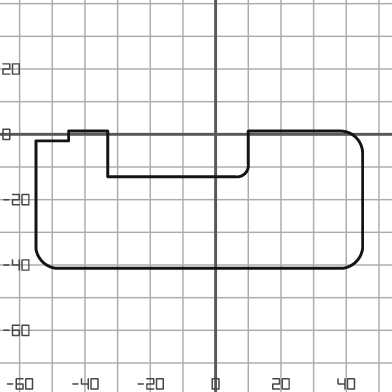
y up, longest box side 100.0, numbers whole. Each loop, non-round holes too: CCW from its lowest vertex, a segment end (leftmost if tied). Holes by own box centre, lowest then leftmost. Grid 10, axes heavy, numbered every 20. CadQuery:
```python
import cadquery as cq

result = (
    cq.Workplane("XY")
    .moveTo(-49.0, -41.0)
    .lineTo(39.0, -41.0)
    .threePointArc((43.0, -39.0), (45.0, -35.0))
    .lineTo(45.0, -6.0)
    .threePointArc((43.0, -1.0), (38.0, 1.0))
    .lineTo(10.0, 1.0)
    .lineTo(10.0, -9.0)
    .threePointArc((9.0, -12.0), (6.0, -13.0))
    .lineTo(-33.0, -13.0)
    .lineTo(-33.0, 1.0)
    .lineTo(-45.0, 1.0)
    .lineTo(-45.0, -2.0)
    .lineTo(-55.0, -2.0)
    .lineTo(-55.0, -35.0)
    .threePointArc((-53.0, -39.0), (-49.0, -41.0))
    .close()
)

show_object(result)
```